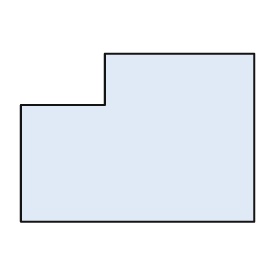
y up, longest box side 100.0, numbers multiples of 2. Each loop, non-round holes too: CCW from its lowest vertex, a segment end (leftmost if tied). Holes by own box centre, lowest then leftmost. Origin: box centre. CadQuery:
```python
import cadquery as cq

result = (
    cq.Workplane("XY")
    .moveTo(-50.0, -36.0)
    .lineTo(50.0, -36.0)
    .lineTo(50.0, 36.0)
    .lineTo(-14.0, 36.0)
    .lineTo(-14.0, 14.0)
    .lineTo(-50.0, 14.0)
    .close()
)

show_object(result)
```